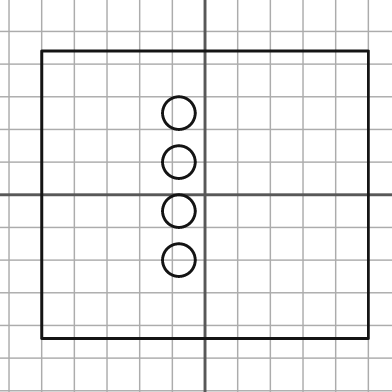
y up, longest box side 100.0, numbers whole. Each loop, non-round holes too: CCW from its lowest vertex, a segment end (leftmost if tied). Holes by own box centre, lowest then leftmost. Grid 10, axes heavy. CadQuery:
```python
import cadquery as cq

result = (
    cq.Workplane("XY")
    .moveTo(-50.0, -44.0)
    .lineTo(50.0, -44.0)
    .lineTo(50.0, 44.0)
    .lineTo(-50.0, 44.0)
    .close()
    .moveTo(-8.0, -20.0)
    .circle(5.0)
    .moveTo(-8.0, -5.0)
    .circle(5.0)
    .moveTo(-8.0, 10.0)
    .circle(5.0)
    .moveTo(-8.0, 25.0)
    .circle(5.0)
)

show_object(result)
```